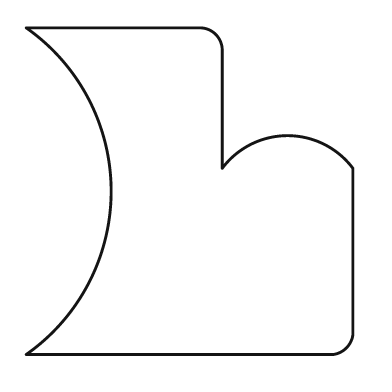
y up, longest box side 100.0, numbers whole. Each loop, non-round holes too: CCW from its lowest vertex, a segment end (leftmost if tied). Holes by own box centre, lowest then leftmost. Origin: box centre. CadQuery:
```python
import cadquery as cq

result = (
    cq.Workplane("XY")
    .moveTo(-50.0, -50.0)
    .lineTo(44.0, -50.0)
    .threePointArc((48.0, -48.0), (50.0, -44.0))
    .lineTo(50.0, 7.0)
    .threePointArc((30.0, 17.0), (10.0, 7.0))
    .lineTo(10.0, 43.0)
    .threePointArc((8.0, 48.0), (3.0, 50.0))
    .lineTo(-50.0, 50.0)
    .threePointArc((-24.0, 0.0), (-50.0, -50.0))
    .close()
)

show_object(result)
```